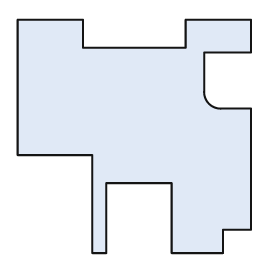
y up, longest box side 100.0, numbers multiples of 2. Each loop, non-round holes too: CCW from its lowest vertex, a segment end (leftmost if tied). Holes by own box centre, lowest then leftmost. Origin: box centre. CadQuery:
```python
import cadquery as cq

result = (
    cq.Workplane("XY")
    .moveTo(-18.0, -50.0)
    .lineTo(-12.0, -50.0)
    .lineTo(-12.0, -20.0)
    .lineTo(16.0, -20.0)
    .lineTo(16.0, -50.0)
    .lineTo(38.0, -50.0)
    .lineTo(38.0, -40.0)
    .lineTo(50.0, -40.0)
    .lineTo(50.0, 12.0)
    .lineTo(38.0, 12.0)
    .threePointArc((32.0, 14.0), (30.0, 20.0))
    .lineTo(30.0, 36.0)
    .lineTo(50.0, 36.0)
    .lineTo(50.0, 50.0)
    .lineTo(22.0, 50.0)
    .lineTo(22.0, 38.0)
    .lineTo(-22.0, 38.0)
    .lineTo(-22.0, 50.0)
    .lineTo(-50.0, 50.0)
    .lineTo(-50.0, -8.0)
    .lineTo(-18.0, -8.0)
    .close()
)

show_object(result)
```